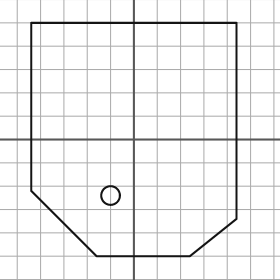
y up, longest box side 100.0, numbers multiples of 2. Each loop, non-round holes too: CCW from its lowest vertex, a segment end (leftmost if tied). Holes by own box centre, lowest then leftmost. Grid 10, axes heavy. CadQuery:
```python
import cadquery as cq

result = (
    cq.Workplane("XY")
    .moveTo(-16.0, -50.0)
    .lineTo(24.0, -50.0)
    .lineTo(44.0, -34.0)
    .lineTo(44.0, 50.0)
    .lineTo(-44.0, 50.0)
    .lineTo(-44.0, -22.0)
    .close()
    .moveTo(-10.0, -24.0)
    .circle(4.0)
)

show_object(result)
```